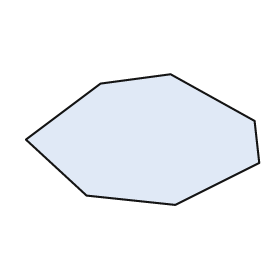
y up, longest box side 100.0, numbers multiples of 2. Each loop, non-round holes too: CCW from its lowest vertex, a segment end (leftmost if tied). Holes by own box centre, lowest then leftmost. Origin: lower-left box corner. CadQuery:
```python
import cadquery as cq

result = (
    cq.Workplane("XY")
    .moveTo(64.0, 0.0)
    .lineTo(100.0, 18.0)
    .lineTo(98.0, 36.0)
    .lineTo(62.0, 56.0)
    .lineTo(32.0, 52.0)
    .lineTo(0.0, 28.0)
    .lineTo(26.0, 4.0)
    .close()
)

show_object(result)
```